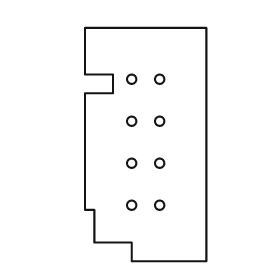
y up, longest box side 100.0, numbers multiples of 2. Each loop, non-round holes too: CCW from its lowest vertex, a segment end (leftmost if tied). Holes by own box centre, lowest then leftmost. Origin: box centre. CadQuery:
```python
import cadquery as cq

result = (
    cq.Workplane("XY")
    .moveTo(-6.0, -50.0)
    .lineTo(26.0, -50.0)
    .lineTo(26.0, 50.0)
    .lineTo(-26.0, 50.0)
    .lineTo(-26.0, 30.0)
    .lineTo(-14.0, 30.0)
    .lineTo(-14.0, 22.0)
    .lineTo(-26.0, 22.0)
    .lineTo(-26.0, -28.0)
    .lineTo(-22.0, -28.0)
    .lineTo(-22.0, -42.0)
    .lineTo(-6.0, -42.0)
    .close()
    .moveTo(-6.0, -26.0)
    .circle(2.0)
    .moveTo(6.0, -26.0)
    .circle(2.0)
    .moveTo(-6.0, -8.0)
    .circle(2.0)
    .moveTo(6.0, -8.0)
    .circle(2.0)
    .moveTo(-6.0, 10.0)
    .circle(2.0)
    .moveTo(6.0, 10.0)
    .circle(2.0)
    .moveTo(-6.0, 28.0)
    .circle(2.0)
    .moveTo(6.0, 28.0)
    .circle(2.0)
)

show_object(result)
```